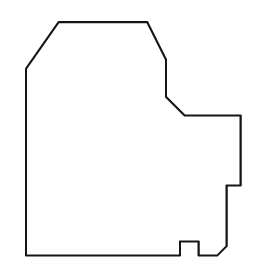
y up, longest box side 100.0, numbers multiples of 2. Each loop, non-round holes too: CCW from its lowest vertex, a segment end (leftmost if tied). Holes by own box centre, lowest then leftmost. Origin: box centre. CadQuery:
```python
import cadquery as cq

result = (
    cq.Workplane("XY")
    .moveTo(-46.0, -50.0)
    .lineTo(20.0, -50.0)
    .lineTo(20.0, -44.0)
    .lineTo(28.0, -44.0)
    .lineTo(28.0, -50.0)
    .lineTo(36.0, -50.0)
    .lineTo(40.0, -46.0)
    .lineTo(40.0, -20.0)
    .lineTo(46.0, -20.0)
    .lineTo(46.0, 10.0)
    .lineTo(22.0, 10.0)
    .lineTo(14.0, 18.0)
    .lineTo(14.0, 34.0)
    .lineTo(6.0, 50.0)
    .lineTo(-32.0, 50.0)
    .lineTo(-46.0, 30.0)
    .close()
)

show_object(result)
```